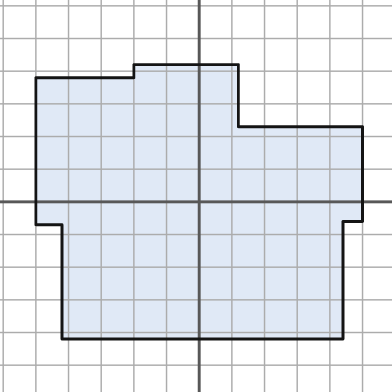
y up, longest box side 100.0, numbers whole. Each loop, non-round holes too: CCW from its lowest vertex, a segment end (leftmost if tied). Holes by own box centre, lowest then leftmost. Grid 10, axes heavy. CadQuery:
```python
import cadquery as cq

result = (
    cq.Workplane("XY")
    .moveTo(-42.0, -42.0)
    .lineTo(44.0, -42.0)
    .lineTo(44.0, -6.0)
    .lineTo(50.0, -6.0)
    .lineTo(50.0, 23.0)
    .lineTo(12.0, 23.0)
    .lineTo(12.0, 42.0)
    .lineTo(-20.0, 42.0)
    .lineTo(-20.0, 38.0)
    .lineTo(-50.0, 38.0)
    .lineTo(-50.0, -7.0)
    .lineTo(-42.0, -7.0)
    .close()
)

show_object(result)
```